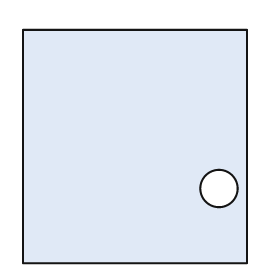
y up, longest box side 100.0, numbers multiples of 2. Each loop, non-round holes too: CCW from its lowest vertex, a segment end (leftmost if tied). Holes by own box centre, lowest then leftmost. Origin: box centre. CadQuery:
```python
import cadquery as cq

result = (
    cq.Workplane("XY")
    .moveTo(-48.0, -50.0)
    .lineTo(48.0, -50.0)
    .lineTo(48.0, 50.0)
    .lineTo(-48.0, 50.0)
    .close()
    .moveTo(36.0, -18.0)
    .circle(8.0)
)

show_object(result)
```